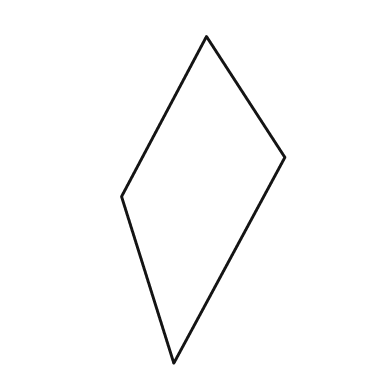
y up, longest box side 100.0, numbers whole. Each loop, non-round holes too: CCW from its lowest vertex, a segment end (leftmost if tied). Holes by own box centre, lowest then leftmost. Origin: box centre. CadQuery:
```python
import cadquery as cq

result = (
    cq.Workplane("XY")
    .moveTo(-9.0, -50.0)
    .lineTo(25.0, 13.0)
    .lineTo(1.0, 50.0)
    .lineTo(-25.0, 1.0)
    .close()
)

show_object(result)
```